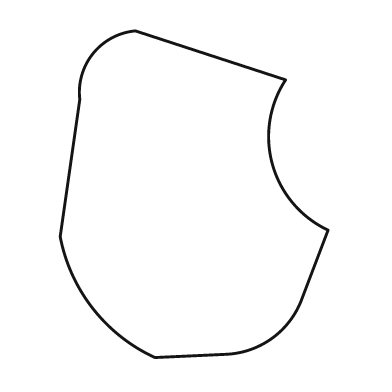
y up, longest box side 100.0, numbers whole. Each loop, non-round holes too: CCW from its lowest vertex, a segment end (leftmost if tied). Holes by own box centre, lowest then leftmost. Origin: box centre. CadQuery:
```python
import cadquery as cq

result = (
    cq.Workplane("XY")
    .moveTo(-12.0, -50.0)
    .lineTo(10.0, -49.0)
    .threePointArc((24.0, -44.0), (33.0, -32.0))
    .lineTo(41.0, -11.0)
    .threePointArc((24.0, 9.0), (28.0, 35.0))
    .lineTo(-18.0, 50.0)
    .threePointArc((-31.0, 43.0), (-35.0, 29.0))
    .lineTo(-41.0, -13.0)
    .threePointArc((-31.0, -35.0), (-12.0, -50.0))
    .close()
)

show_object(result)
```